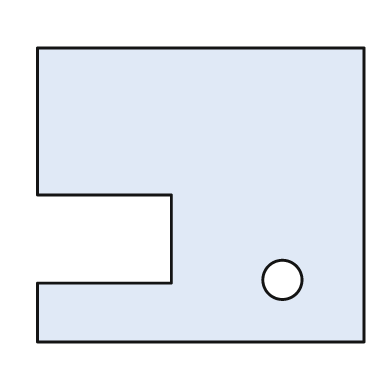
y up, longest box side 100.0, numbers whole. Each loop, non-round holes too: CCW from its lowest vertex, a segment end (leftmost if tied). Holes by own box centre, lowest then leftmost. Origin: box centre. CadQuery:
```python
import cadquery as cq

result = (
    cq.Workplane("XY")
    .moveTo(-50.0, -45.0)
    .lineTo(50.0, -45.0)
    .lineTo(50.0, 45.0)
    .lineTo(-50.0, 45.0)
    .lineTo(-50.0, 0.0)
    .lineTo(-9.0, 0.0)
    .lineTo(-9.0, -27.0)
    .lineTo(-50.0, -27.0)
    .close()
    .moveTo(25.0, -26.0)
    .circle(6.0)
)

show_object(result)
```